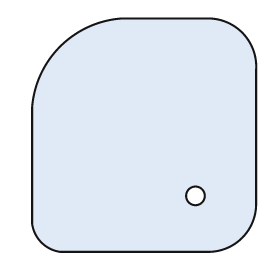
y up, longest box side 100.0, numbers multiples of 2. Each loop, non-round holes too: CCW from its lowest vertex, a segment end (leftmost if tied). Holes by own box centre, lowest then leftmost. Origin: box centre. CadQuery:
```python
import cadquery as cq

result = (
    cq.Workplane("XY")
    .moveTo(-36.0, -50.0)
    .lineTo(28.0, -50.0)
    .threePointArc((42.0, -44.0), (48.0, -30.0))
    .lineTo(48.0, 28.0)
    .threePointArc((42.0, 44.0), (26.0, 50.0))
    .lineTo(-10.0, 50.0)
    .threePointArc((-36.0, 38.0), (-48.0, 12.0))
    .lineTo(-48.0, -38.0)
    .threePointArc((-44.0, -46.0), (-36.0, -50.0))
    .close()
    .moveTo(22.0, -26.0)
    .circle(4.0)
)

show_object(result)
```